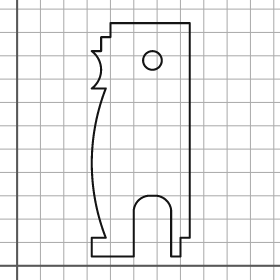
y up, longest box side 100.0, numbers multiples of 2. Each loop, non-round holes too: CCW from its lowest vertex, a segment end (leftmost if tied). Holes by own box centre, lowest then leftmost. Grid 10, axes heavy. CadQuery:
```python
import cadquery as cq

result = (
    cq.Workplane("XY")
    .moveTo(32.0, 4.0)
    .lineTo(50.0, 4.0)
    .lineTo(50.0, 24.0)
    .threePointArc((52.0, 28.0), (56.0, 30.0))
    .lineTo(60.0, 30.0)
    .threePointArc((64.0, 28.0), (66.0, 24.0))
    .lineTo(66.0, 4.0)
    .lineTo(70.0, 4.0)
    .lineTo(70.0, 12.0)
    .lineTo(74.0, 12.0)
    .lineTo(74.0, 104.0)
    .lineTo(40.0, 104.0)
    .lineTo(40.0, 98.0)
    .lineTo(36.0, 98.0)
    .lineTo(36.0, 92.0)
    .lineTo(32.0, 92.0)
    .threePointArc((36.0, 84.0), (32.0, 76.0))
    .lineTo(38.0, 76.0)
    .threePointArc((32.0, 44.0), (38.0, 12.0))
    .lineTo(32.0, 12.0)
    .close()
    .moveTo(58.0, 88.0)
    .circle(4.0)
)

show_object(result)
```